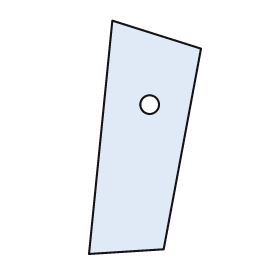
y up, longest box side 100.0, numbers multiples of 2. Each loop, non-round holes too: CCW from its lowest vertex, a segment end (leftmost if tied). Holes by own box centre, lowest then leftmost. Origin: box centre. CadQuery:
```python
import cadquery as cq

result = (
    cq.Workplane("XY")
    .moveTo(-24.0, -50.0)
    .lineTo(8.0, -48.0)
    .lineTo(24.0, 38.0)
    .lineTo(-14.0, 50.0)
    .close()
    .moveTo(2.0, 14.0)
    .circle(4.0)
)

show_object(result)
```